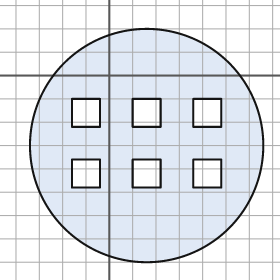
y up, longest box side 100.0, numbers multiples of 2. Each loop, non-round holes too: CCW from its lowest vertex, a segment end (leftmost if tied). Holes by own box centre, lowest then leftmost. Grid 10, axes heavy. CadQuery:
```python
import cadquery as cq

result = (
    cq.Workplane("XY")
    .moveTo(16.0, -30.0)
    .circle(50.0)
    .moveTo(-16.0, -48.0)
    .lineTo(-4.0, -48.0)
    .lineTo(-4.0, -36.0)
    .lineTo(-16.0, -36.0)
    .close()
    .moveTo(10.0, -48.0)
    .lineTo(22.0, -48.0)
    .lineTo(22.0, -36.0)
    .lineTo(10.0, -36.0)
    .close()
    .moveTo(36.0, -48.0)
    .lineTo(48.0, -48.0)
    .lineTo(48.0, -36.0)
    .lineTo(36.0, -36.0)
    .close()
    .moveTo(-16.0, -22.0)
    .lineTo(-4.0, -22.0)
    .lineTo(-4.0, -10.0)
    .lineTo(-16.0, -10.0)
    .close()
    .moveTo(10.0, -22.0)
    .lineTo(22.0, -22.0)
    .lineTo(22.0, -10.0)
    .lineTo(10.0, -10.0)
    .close()
    .moveTo(36.0, -22.0)
    .lineTo(48.0, -22.0)
    .lineTo(48.0, -10.0)
    .lineTo(36.0, -10.0)
    .close()
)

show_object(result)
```